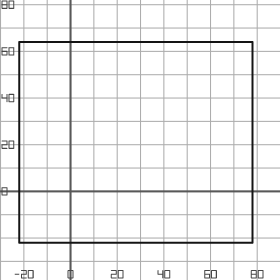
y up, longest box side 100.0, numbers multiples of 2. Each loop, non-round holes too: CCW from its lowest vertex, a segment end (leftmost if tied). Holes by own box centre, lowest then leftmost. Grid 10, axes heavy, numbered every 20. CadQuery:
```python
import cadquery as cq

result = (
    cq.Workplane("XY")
    .moveTo(-22.0, -22.0)
    .lineTo(78.0, -22.0)
    .lineTo(78.0, 64.0)
    .lineTo(-22.0, 64.0)
    .close()
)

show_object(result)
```